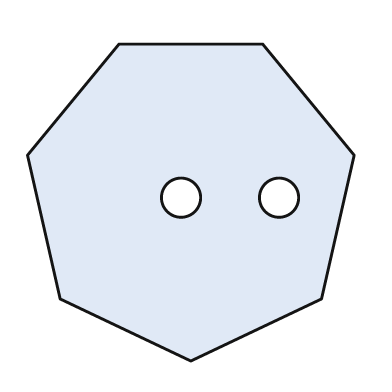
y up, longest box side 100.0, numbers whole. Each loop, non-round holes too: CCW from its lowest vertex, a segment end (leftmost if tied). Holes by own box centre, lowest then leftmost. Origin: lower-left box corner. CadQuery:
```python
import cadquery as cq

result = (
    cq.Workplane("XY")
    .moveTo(50.0, 0.0)
    .lineTo(90.0, 19.0)
    .lineTo(100.0, 63.0)
    .lineTo(72.0, 97.0)
    .lineTo(28.0, 97.0)
    .lineTo(0.0, 63.0)
    .lineTo(10.0, 19.0)
    .close()
    .moveTo(47.0, 50.0)
    .circle(6.0)
    .moveTo(77.0, 50.0)
    .circle(6.0)
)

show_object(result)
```